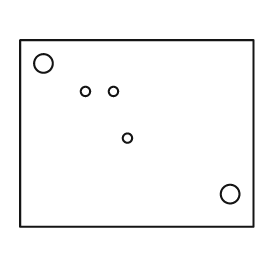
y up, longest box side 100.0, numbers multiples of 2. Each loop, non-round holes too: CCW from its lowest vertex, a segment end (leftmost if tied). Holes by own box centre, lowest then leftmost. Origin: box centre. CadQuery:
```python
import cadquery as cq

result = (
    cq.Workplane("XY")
    .moveTo(-50.0, -40.0)
    .lineTo(50.0, -40.0)
    .lineTo(50.0, 40.0)
    .lineTo(-50.0, 40.0)
    .close()
    .moveTo(40.0, -26.0)
    .circle(4.0)
    .moveTo(-4.0, -2.0)
    .circle(2.0)
    .moveTo(-22.0, 18.0)
    .circle(2.0)
    .moveTo(-10.0, 18.0)
    .circle(2.0)
    .moveTo(-40.0, 30.0)
    .circle(4.0)
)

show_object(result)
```